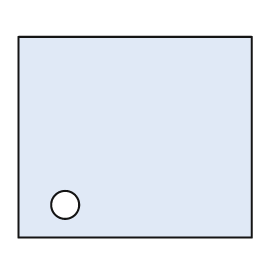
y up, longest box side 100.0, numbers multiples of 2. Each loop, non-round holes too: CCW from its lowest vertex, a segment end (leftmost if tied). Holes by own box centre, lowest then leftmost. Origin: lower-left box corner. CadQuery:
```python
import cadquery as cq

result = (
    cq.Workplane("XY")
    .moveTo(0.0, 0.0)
    .lineTo(100.0, 0.0)
    .lineTo(100.0, 86.0)
    .lineTo(0.0, 86.0)
    .close()
    .moveTo(20.0, 14.0)
    .circle(6.0)
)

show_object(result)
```